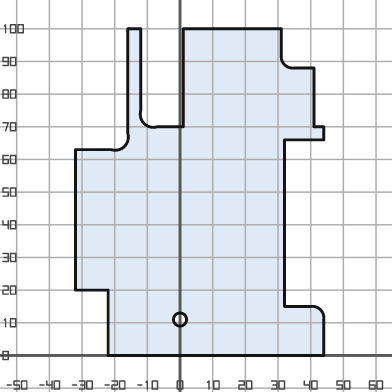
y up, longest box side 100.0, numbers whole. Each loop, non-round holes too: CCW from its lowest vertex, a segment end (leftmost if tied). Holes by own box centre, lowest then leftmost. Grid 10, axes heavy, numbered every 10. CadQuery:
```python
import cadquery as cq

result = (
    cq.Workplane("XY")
    .moveTo(-22.0, 0.0)
    .lineTo(44.0, 0.0)
    .lineTo(44.0, 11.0)
    .threePointArc((43.0, 14.0), (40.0, 15.0))
    .lineTo(32.0, 15.0)
    .lineTo(32.0, 66.0)
    .lineTo(44.0, 66.0)
    .lineTo(44.0, 70.0)
    .lineTo(41.0, 70.0)
    .lineTo(41.0, 88.0)
    .lineTo(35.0, 88.0)
    .threePointArc((32.0, 89.0), (31.0, 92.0))
    .lineTo(31.0, 100.0)
    .lineTo(1.0, 100.0)
    .lineTo(1.0, 70.0)
    .lineTo(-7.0, 70.0)
    .threePointArc((-11.0, 71.0), (-12.0, 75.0))
    .lineTo(-12.0, 100.0)
    .lineTo(-16.0, 100.0)
    .lineTo(-16.0, 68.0)
    .threePointArc((-17.0, 64.0), (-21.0, 63.0))
    .lineTo(-32.0, 63.0)
    .lineTo(-32.0, 20.0)
    .lineTo(-22.0, 20.0)
    .close()
    .moveTo(0.0, 11.0)
    .circle(2.0)
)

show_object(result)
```